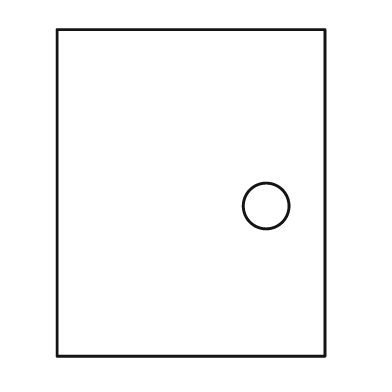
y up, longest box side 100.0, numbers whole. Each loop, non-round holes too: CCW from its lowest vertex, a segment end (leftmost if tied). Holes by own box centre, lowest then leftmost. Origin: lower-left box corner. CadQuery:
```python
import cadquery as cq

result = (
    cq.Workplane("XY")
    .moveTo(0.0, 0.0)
    .lineTo(82.0, 0.0)
    .lineTo(82.0, 100.0)
    .lineTo(0.0, 100.0)
    .close()
    .moveTo(64.0, 46.0)
    .circle(7.0)
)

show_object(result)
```